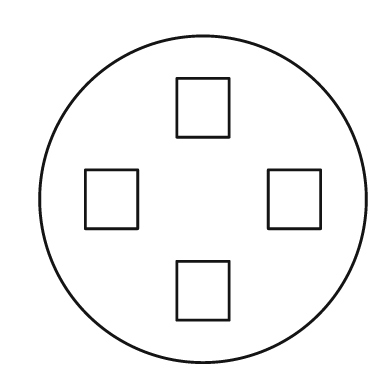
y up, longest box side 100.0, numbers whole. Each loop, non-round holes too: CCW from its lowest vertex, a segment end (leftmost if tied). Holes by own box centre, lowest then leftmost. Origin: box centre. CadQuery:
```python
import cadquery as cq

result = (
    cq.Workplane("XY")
    .moveTo(0.0, 0.0)
    .circle(50.0)
    .moveTo(-8.0, -37.0)
    .lineTo(8.0, -37.0)
    .lineTo(8.0, -19.0)
    .lineTo(-8.0, -19.0)
    .close()
    .moveTo(-36.0, -9.0)
    .lineTo(-20.0, -9.0)
    .lineTo(-20.0, 9.0)
    .lineTo(-36.0, 9.0)
    .close()
    .moveTo(20.0, -9.0)
    .lineTo(36.0, -9.0)
    .lineTo(36.0, 9.0)
    .lineTo(20.0, 9.0)
    .close()
    .moveTo(-8.0, 19.0)
    .lineTo(8.0, 19.0)
    .lineTo(8.0, 37.0)
    .lineTo(-8.0, 37.0)
    .close()
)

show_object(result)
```